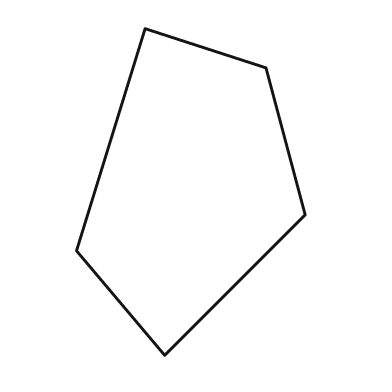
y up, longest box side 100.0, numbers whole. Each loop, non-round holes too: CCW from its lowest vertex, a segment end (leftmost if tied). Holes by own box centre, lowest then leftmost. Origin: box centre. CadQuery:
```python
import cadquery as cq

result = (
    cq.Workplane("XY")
    .moveTo(-8.0, -50.0)
    .lineTo(35.0, -7.0)
    .lineTo(23.0, 38.0)
    .lineTo(-14.0, 50.0)
    .lineTo(-35.0, -18.0)
    .close()
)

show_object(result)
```